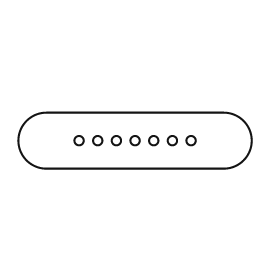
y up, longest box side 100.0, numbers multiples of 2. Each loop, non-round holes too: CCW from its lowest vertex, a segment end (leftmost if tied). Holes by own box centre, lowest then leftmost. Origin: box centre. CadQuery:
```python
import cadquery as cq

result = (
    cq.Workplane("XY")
    .moveTo(-38.0, -12.0)
    .lineTo(38.0, -12.0)
    .threePointArc((50.0, 0.0), (38.0, 12.0))
    .lineTo(-38.0, 12.0)
    .threePointArc((-50.0, 0.0), (-38.0, -12.0))
    .close()
    .moveTo(-24.0, 0.0)
    .circle(2.0)
    .moveTo(-16.0, 0.0)
    .circle(2.0)
    .moveTo(-8.0, 0.0)
    .circle(2.0)
    .moveTo(0.0, 0.0)
    .circle(2.0)
    .moveTo(8.0, 0.0)
    .circle(2.0)
    .moveTo(16.0, 0.0)
    .circle(2.0)
    .moveTo(24.0, 0.0)
    .circle(2.0)
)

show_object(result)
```